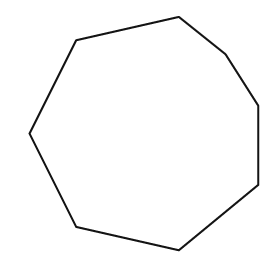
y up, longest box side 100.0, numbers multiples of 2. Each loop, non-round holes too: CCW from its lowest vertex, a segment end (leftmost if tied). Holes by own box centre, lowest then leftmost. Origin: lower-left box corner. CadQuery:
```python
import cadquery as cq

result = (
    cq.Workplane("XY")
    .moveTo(64.0, 0.0)
    .lineTo(98.0, 28.0)
    .lineTo(98.0, 62.0)
    .lineTo(84.0, 84.0)
    .lineTo(64.0, 100.0)
    .lineTo(20.0, 90.0)
    .lineTo(0.0, 50.0)
    .lineTo(20.0, 10.0)
    .close()
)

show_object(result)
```